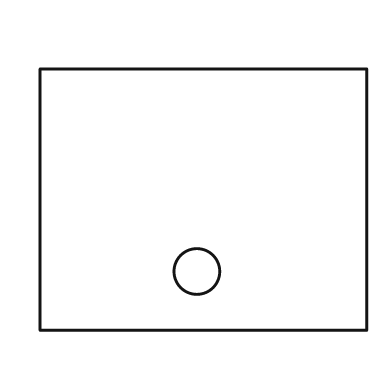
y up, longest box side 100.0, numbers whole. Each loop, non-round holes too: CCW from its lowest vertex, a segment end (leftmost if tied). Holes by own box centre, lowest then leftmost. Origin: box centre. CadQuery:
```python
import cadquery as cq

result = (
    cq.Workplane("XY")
    .moveTo(-50.0, -40.0)
    .lineTo(50.0, -40.0)
    .lineTo(50.0, 40.0)
    .lineTo(-50.0, 40.0)
    .close()
    .moveTo(-2.0, -22.0)
    .circle(7.0)
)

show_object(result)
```